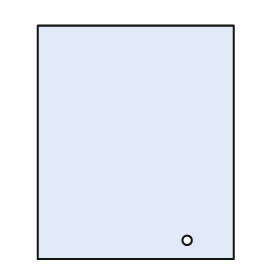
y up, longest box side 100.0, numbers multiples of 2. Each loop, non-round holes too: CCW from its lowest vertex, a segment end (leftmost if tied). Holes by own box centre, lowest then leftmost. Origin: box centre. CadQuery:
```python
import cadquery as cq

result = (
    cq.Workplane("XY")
    .moveTo(-42.0, -50.0)
    .lineTo(42.0, -50.0)
    .lineTo(42.0, 50.0)
    .lineTo(-42.0, 50.0)
    .close()
    .moveTo(22.0, -42.0)
    .circle(2.0)
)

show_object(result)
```